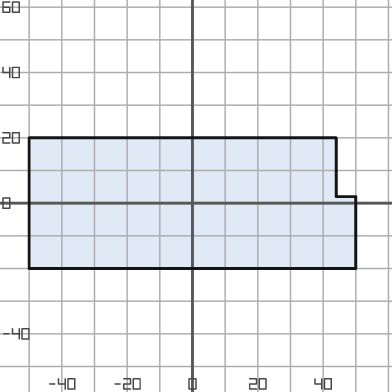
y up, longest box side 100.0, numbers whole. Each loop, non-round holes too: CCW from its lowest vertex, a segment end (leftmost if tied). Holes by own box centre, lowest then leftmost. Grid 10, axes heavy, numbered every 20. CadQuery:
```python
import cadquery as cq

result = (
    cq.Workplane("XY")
    .moveTo(-50.0, -20.0)
    .lineTo(50.0, -20.0)
    .lineTo(50.0, 2.0)
    .lineTo(44.0, 2.0)
    .lineTo(44.0, 20.0)
    .lineTo(-50.0, 20.0)
    .close()
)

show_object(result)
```